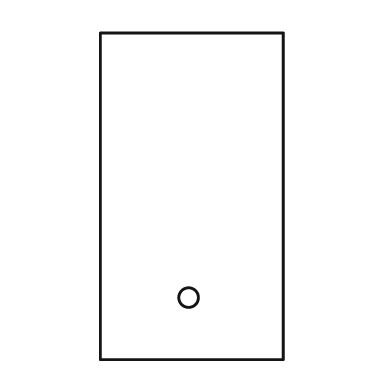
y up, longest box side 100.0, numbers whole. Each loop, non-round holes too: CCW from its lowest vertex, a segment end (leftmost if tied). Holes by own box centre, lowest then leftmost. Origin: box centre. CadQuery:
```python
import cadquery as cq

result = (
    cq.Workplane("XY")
    .moveTo(-28.0, -50.0)
    .lineTo(28.0, -50.0)
    .lineTo(28.0, 50.0)
    .lineTo(-28.0, 50.0)
    .close()
    .moveTo(-1.0, -31.0)
    .circle(3.0)
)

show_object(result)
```